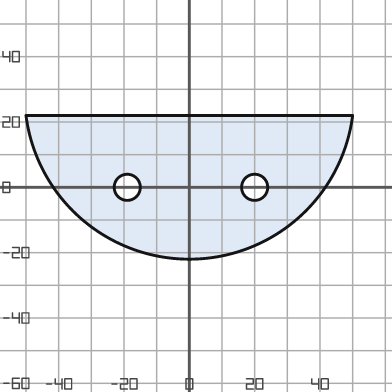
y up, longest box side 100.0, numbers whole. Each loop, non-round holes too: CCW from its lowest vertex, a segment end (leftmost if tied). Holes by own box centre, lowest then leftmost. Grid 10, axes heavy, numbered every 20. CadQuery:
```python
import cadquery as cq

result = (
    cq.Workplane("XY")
    .moveTo(-50.0, 22.0)
    .threePointArc((0.0, -22.0), (50.0, 22.0))
    .close()
    .moveTo(-19.0, 0.0)
    .circle(4.0)
    .moveTo(20.0, 0.0)
    .circle(4.0)
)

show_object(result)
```